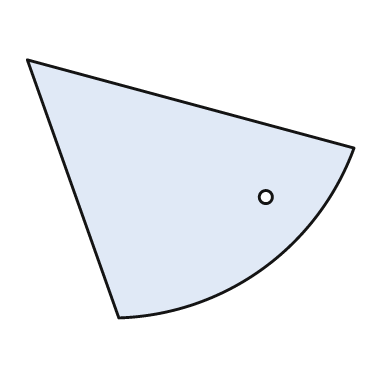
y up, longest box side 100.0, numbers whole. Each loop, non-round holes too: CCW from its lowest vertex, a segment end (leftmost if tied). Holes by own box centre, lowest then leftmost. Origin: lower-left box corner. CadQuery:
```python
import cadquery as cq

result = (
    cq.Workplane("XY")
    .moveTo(28.0, 0.0)
    .threePointArc((72.0, 15.0), (100.0, 52.0))
    .lineTo(0.0, 79.0)
    .close()
    .moveTo(73.0, 37.0)
    .circle(2.0)
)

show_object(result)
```